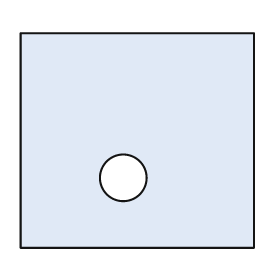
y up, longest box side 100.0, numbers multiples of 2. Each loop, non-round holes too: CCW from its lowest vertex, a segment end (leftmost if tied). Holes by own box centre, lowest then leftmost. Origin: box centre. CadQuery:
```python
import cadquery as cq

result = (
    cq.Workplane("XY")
    .moveTo(-50.0, -46.0)
    .lineTo(50.0, -46.0)
    .lineTo(50.0, 46.0)
    .lineTo(-50.0, 46.0)
    .close()
    .moveTo(-6.0, -16.0)
    .circle(10.0)
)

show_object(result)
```